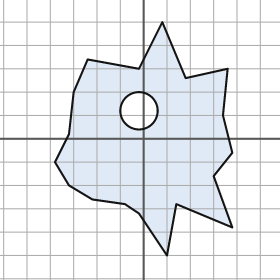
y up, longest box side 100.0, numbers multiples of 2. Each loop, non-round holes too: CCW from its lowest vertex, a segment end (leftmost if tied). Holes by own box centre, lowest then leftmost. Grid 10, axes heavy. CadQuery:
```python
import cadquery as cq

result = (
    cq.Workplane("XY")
    .moveTo(10.0, -50.0)
    .lineTo(14.0, -28.0)
    .lineTo(38.0, -38.0)
    .lineTo(30.0, -16.0)
    .lineTo(38.0, -6.0)
    .lineTo(34.0, 10.0)
    .lineTo(36.0, 30.0)
    .lineTo(18.0, 26.0)
    .lineTo(8.0, 50.0)
    .lineTo(-2.0, 30.0)
    .lineTo(-24.0, 34.0)
    .lineTo(-30.0, 20.0)
    .lineTo(-32.0, 2.0)
    .lineTo(-38.0, -10.0)
    .lineTo(-32.0, -20.0)
    .lineTo(-22.0, -26.0)
    .lineTo(-8.0, -28.0)
    .lineTo(-2.0, -32.0)
    .close()
    .moveTo(-2.0, 12.0)
    .circle(8.0)
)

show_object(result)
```